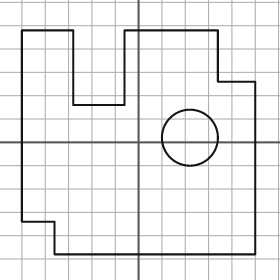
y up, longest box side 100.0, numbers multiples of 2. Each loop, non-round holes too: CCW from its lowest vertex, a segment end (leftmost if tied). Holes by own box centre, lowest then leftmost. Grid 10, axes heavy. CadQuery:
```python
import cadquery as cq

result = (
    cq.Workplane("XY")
    .moveTo(-36.0, -48.0)
    .lineTo(50.0, -48.0)
    .lineTo(50.0, 26.0)
    .lineTo(34.0, 26.0)
    .lineTo(34.0, 48.0)
    .lineTo(-6.0, 48.0)
    .lineTo(-6.0, 16.0)
    .lineTo(-28.0, 16.0)
    .lineTo(-28.0, 48.0)
    .lineTo(-50.0, 48.0)
    .lineTo(-50.0, -34.0)
    .lineTo(-36.0, -34.0)
    .close()
    .moveTo(22.0, 2.0)
    .circle(12.0)
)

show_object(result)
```